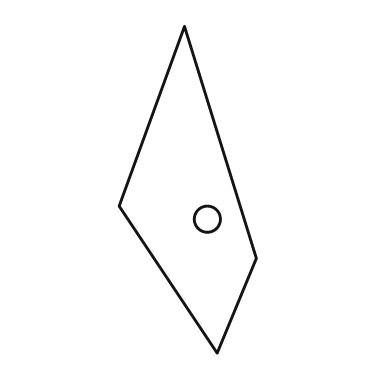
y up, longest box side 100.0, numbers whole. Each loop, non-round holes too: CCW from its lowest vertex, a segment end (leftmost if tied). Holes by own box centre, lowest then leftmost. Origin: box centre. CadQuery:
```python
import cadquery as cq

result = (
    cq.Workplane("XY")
    .moveTo(9.0, -50.0)
    .lineTo(21.0, -21.0)
    .lineTo(-1.0, 50.0)
    .lineTo(-21.0, -5.0)
    .close()
    .moveTo(6.0, -9.0)
    .circle(4.0)
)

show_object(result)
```